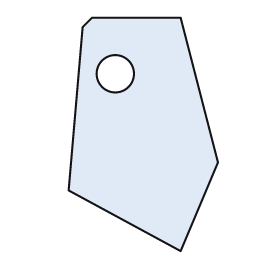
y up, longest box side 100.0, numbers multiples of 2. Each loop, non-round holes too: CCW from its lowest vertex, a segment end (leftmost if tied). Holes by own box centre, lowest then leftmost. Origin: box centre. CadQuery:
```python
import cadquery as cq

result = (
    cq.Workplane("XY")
    .moveTo(16.0, -50.0)
    .lineTo(32.0, -12.0)
    .lineTo(16.0, 50.0)
    .lineTo(-22.0, 50.0)
    .lineTo(-26.0, 46.0)
    .lineTo(-32.0, -24.0)
    .close()
    .moveTo(-12.0, 26.0)
    .circle(8.0)
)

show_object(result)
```